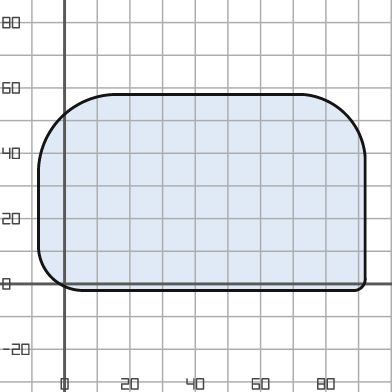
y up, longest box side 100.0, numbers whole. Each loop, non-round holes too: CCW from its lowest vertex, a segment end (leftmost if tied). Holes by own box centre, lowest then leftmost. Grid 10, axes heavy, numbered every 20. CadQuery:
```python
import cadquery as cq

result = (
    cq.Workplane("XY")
    .moveTo(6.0, -2.0)
    .lineTo(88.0, -2.0)
    .threePointArc((91.0, -1.0), (92.0, 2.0))
    .lineTo(92.0, 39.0)
    .threePointArc((86.0, 52.0), (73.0, 58.0))
    .lineTo(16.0, 58.0)
    .threePointArc((-1.0, 51.0), (-8.0, 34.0))
    .lineTo(-8.0, 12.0)
    .threePointArc((-4.0, 2.0), (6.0, -2.0))
    .close()
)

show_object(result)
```